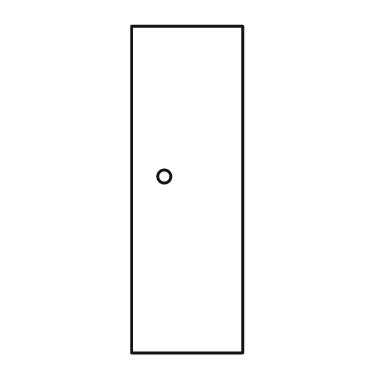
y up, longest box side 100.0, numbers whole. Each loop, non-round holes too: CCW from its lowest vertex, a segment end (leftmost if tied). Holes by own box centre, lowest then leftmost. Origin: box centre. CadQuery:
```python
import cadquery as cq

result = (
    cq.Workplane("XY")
    .moveTo(-17.0, -50.0)
    .lineTo(17.0, -50.0)
    .lineTo(17.0, 50.0)
    .lineTo(-17.0, 50.0)
    .close()
    .moveTo(-7.0, 4.0)
    .circle(2.0)
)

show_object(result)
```